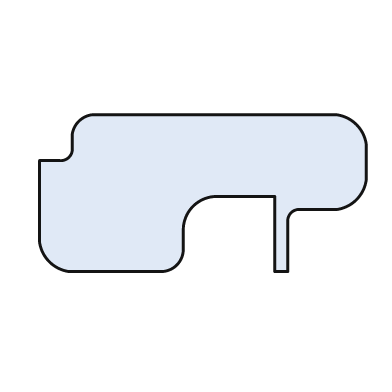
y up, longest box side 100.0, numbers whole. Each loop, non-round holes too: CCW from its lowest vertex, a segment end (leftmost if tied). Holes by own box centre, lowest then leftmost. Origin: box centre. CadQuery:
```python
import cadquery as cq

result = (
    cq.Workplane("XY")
    .moveTo(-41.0, -24.0)
    .lineTo(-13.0, -24.0)
    .threePointArc((-8.0, -22.0), (-6.0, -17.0))
    .lineTo(-6.0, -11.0)
    .threePointArc((-3.0, -4.0), (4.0, -1.0))
    .lineTo(22.0, -1.0)
    .lineTo(22.0, -24.0)
    .lineTo(26.0, -24.0)
    .lineTo(26.0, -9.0)
    .threePointArc((27.0, -6.0), (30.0, -5.0))
    .lineTo(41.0, -5.0)
    .threePointArc((47.0, -2.0), (50.0, 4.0))
    .lineTo(50.0, 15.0)
    .threePointArc((47.0, 21.0), (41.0, 24.0))
    .lineTo(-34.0, 24.0)
    .threePointArc((-38.0, 22.0), (-40.0, 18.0))
    .lineTo(-40.0, 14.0)
    .threePointArc((-41.0, 11.0), (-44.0, 10.0))
    .lineTo(-50.0, 10.0)
    .lineTo(-50.0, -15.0)
    .threePointArc((-47.0, -21.0), (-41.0, -24.0))
    .close()
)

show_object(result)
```